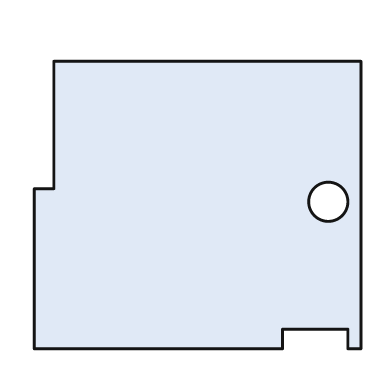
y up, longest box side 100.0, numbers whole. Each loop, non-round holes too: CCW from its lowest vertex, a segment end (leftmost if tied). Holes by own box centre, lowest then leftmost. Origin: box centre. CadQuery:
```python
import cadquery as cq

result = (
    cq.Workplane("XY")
    .moveTo(-50.0, -44.0)
    .lineTo(26.0, -44.0)
    .lineTo(26.0, -38.0)
    .lineTo(46.0, -38.0)
    .lineTo(46.0, -44.0)
    .lineTo(50.0, -44.0)
    .lineTo(50.0, 44.0)
    .lineTo(-44.0, 44.0)
    .lineTo(-44.0, 5.0)
    .lineTo(-50.0, 5.0)
    .close()
    .moveTo(40.0, 1.0)
    .circle(6.0)
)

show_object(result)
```